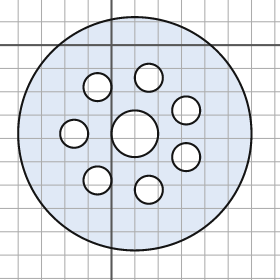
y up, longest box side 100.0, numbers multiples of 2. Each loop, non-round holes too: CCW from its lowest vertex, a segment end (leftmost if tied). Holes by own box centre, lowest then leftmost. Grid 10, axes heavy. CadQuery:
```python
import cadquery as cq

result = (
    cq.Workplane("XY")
    .moveTo(10.0, -38.0)
    .circle(50.0)
    .moveTo(16.0, -62.0)
    .circle(6.0)
    .moveTo(-6.0, -58.0)
    .circle(6.0)
    .moveTo(32.0, -48.0)
    .circle(6.0)
    .moveTo(-16.0, -38.0)
    .circle(6.0)
    .moveTo(10.0, -38.0)
    .circle(10.0)
    .moveTo(32.0, -28.0)
    .circle(6.0)
    .moveTo(-6.0, -18.0)
    .circle(6.0)
    .moveTo(16.0, -14.0)
    .circle(6.0)
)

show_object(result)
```